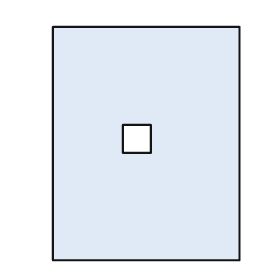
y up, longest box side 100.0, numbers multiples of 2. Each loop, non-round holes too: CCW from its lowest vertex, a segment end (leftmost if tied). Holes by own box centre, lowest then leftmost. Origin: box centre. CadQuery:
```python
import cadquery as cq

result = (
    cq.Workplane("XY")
    .moveTo(-40.0, -50.0)
    .lineTo(40.0, -50.0)
    .lineTo(40.0, 50.0)
    .lineTo(-40.0, 50.0)
    .close()
    .moveTo(-10.0, -4.0)
    .lineTo(2.0, -4.0)
    .lineTo(2.0, 8.0)
    .lineTo(-10.0, 8.0)
    .close()
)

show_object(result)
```